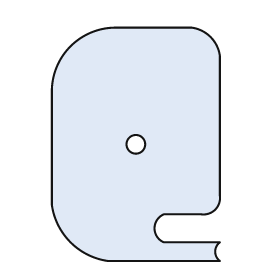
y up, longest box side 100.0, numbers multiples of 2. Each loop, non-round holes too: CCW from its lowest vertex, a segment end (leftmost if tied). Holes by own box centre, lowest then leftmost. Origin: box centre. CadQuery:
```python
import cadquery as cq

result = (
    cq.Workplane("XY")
    .moveTo(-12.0, -50.0)
    .lineTo(36.0, -50.0)
    .threePointArc((34.0, -46.0), (36.0, -42.0))
    .lineTo(12.0, -42.0)
    .threePointArc((8.0, -36.0), (12.0, -30.0))
    .lineTo(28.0, -30.0)
    .threePointArc((34.0, -28.0), (36.0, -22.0))
    .lineTo(36.0, 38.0)
    .threePointArc((32.0, 46.0), (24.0, 50.0))
    .lineTo(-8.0, 50.0)
    .threePointArc((-28.0, 42.0), (-36.0, 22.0))
    .lineTo(-36.0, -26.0)
    .threePointArc((-28.0, -42.0), (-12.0, -50.0))
    .close()
    .moveTo(0.0, 0.0)
    .circle(4.0)
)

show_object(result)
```